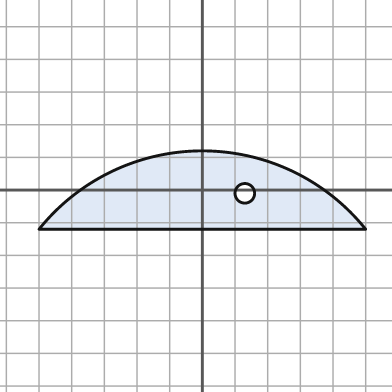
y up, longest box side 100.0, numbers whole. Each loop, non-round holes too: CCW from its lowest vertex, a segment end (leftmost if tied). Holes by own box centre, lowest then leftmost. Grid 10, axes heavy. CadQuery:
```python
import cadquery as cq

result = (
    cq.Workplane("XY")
    .moveTo(-50.0, -12.0)
    .lineTo(50.0, -12.0)
    .threePointArc((0.0, 12.0), (-50.0, -12.0))
    .close()
    .moveTo(13.0, -1.0)
    .circle(3.0)
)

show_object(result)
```